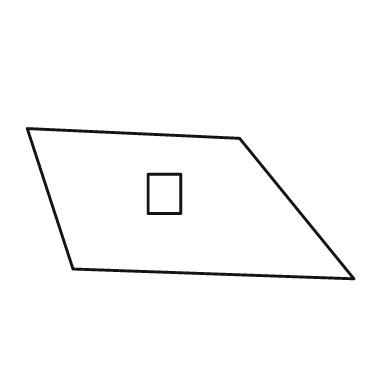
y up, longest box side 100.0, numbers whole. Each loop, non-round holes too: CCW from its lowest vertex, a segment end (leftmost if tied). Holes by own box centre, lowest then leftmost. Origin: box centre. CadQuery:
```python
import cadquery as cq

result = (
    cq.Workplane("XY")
    .moveTo(50.0, -23.0)
    .lineTo(15.0, 20.0)
    .lineTo(-50.0, 23.0)
    .lineTo(-36.0, -20.0)
    .close()
    .moveTo(-13.0, -3.0)
    .lineTo(-3.0, -3.0)
    .lineTo(-3.0, 9.0)
    .lineTo(-13.0, 9.0)
    .close()
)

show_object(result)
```